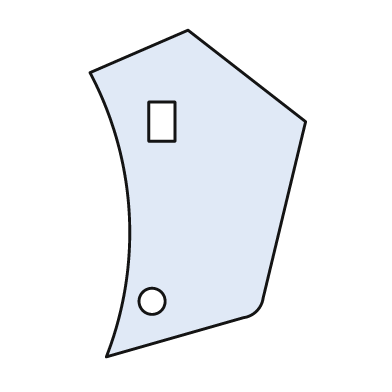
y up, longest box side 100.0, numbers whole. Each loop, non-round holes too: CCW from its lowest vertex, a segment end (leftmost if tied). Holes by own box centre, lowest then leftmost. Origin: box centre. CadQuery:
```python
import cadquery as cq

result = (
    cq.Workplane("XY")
    .moveTo(-28.0, -50.0)
    .lineTo(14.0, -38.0)
    .threePointArc((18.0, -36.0), (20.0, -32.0))
    .lineTo(33.0, 22.0)
    .lineTo(-3.0, 50.0)
    .lineTo(-33.0, 37.0)
    .threePointArc((-21.0, -6.0), (-28.0, -50.0))
    .close()
    .moveTo(-14.0, -33.0)
    .circle(4.0)
    .moveTo(-15.0, 16.0)
    .lineTo(-7.0, 16.0)
    .lineTo(-7.0, 28.0)
    .lineTo(-15.0, 28.0)
    .close()
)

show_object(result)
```